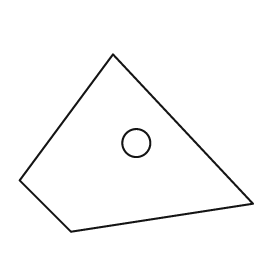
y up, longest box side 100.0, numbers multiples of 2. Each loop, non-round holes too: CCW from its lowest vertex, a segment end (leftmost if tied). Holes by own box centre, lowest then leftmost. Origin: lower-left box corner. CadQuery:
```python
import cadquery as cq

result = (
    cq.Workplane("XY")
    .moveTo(22.0, 0.0)
    .lineTo(100.0, 12.0)
    .lineTo(40.0, 76.0)
    .lineTo(0.0, 22.0)
    .close()
    .moveTo(50.0, 38.0)
    .circle(6.0)
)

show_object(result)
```